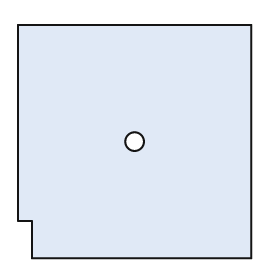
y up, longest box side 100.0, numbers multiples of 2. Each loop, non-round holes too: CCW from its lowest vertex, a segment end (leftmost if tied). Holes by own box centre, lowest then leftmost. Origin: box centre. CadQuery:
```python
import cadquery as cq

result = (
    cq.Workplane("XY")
    .moveTo(-44.0, -50.0)
    .lineTo(50.0, -50.0)
    .lineTo(50.0, 50.0)
    .lineTo(-50.0, 50.0)
    .lineTo(-50.0, -34.0)
    .lineTo(-44.0, -34.0)
    .close()
    .moveTo(0.0, 0.0)
    .circle(4.0)
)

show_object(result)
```